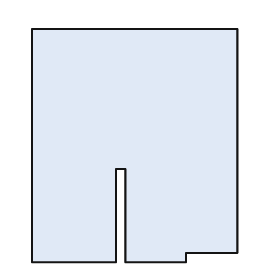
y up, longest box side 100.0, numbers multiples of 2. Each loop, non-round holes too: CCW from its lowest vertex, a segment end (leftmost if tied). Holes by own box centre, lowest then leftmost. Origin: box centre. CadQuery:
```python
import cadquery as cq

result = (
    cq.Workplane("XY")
    .moveTo(-44.0, -50.0)
    .lineTo(-8.0, -50.0)
    .lineTo(-8.0, -10.0)
    .lineTo(-4.0, -10.0)
    .lineTo(-4.0, -50.0)
    .lineTo(22.0, -50.0)
    .lineTo(22.0, -46.0)
    .lineTo(44.0, -46.0)
    .lineTo(44.0, 50.0)
    .lineTo(-44.0, 50.0)
    .close()
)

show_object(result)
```